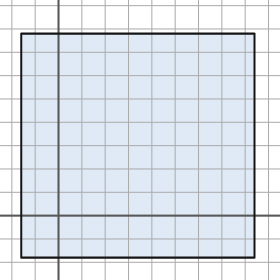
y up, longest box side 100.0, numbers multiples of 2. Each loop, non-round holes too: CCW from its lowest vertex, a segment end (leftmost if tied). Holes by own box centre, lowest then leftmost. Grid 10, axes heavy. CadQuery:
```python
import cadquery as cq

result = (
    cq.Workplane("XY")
    .moveTo(-16.0, -18.0)
    .lineTo(84.0, -18.0)
    .lineTo(84.0, 78.0)
    .lineTo(-16.0, 78.0)
    .close()
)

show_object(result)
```